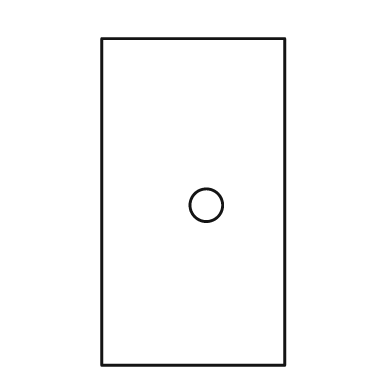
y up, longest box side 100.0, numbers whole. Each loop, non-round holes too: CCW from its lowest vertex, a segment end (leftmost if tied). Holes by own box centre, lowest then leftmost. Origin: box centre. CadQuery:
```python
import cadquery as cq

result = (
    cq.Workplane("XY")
    .moveTo(-28.0, -50.0)
    .lineTo(28.0, -50.0)
    .lineTo(28.0, 50.0)
    .lineTo(-28.0, 50.0)
    .close()
    .moveTo(4.0, -1.0)
    .circle(5.0)
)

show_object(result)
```